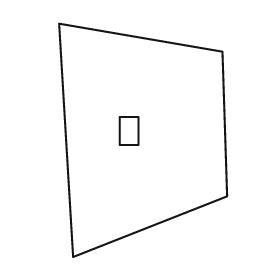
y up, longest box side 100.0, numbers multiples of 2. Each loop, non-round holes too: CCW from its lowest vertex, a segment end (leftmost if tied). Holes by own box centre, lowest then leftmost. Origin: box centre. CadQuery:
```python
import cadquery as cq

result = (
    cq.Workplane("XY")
    .moveTo(-30.0, -50.0)
    .lineTo(36.0, -24.0)
    .lineTo(34.0, 38.0)
    .lineTo(-36.0, 50.0)
    .close()
    .moveTo(-10.0, -2.0)
    .lineTo(-2.0, -2.0)
    .lineTo(-2.0, 10.0)
    .lineTo(-10.0, 10.0)
    .close()
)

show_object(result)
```